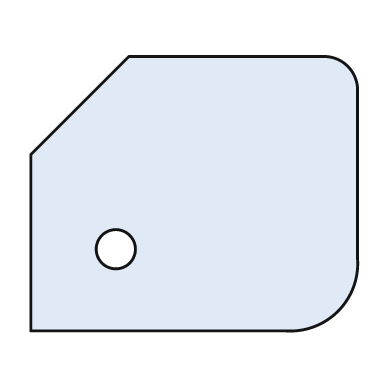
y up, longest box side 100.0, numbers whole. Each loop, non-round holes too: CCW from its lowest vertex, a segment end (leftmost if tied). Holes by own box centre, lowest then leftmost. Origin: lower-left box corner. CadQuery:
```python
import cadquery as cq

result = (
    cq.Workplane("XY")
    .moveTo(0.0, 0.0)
    .lineTo(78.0, 0.0)
    .threePointArc((94.0, 6.0), (100.0, 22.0))
    .lineTo(100.0, 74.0)
    .threePointArc((97.0, 81.0), (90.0, 84.0))
    .lineTo(30.0, 84.0)
    .lineTo(0.0, 54.0)
    .close()
    .moveTo(26.0, 25.0)
    .circle(6.0)
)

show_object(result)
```